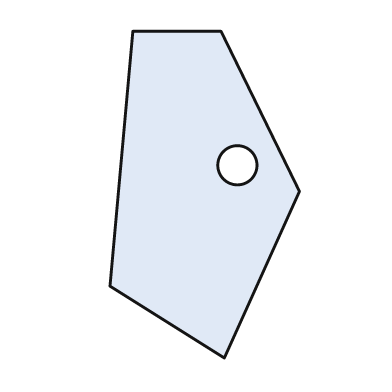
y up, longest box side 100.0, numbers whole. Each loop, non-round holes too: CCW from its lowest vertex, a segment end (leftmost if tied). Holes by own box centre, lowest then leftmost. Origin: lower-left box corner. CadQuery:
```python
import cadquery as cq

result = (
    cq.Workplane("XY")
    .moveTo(35.0, 0.0)
    .lineTo(58.0, 51.0)
    .lineTo(34.0, 100.0)
    .lineTo(7.0, 100.0)
    .lineTo(0.0, 22.0)
    .close()
    .moveTo(39.0, 59.0)
    .circle(6.0)
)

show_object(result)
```